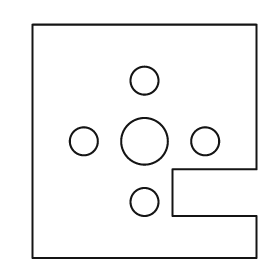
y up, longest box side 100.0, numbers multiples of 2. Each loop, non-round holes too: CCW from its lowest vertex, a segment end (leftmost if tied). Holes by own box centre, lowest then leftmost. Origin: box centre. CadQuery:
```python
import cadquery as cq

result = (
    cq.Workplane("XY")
    .moveTo(-48.0, -50.0)
    .lineTo(48.0, -50.0)
    .lineTo(48.0, -32.0)
    .lineTo(12.0, -32.0)
    .lineTo(12.0, -12.0)
    .lineTo(48.0, -12.0)
    .lineTo(48.0, 50.0)
    .lineTo(-48.0, 50.0)
    .close()
    .moveTo(0.0, -26.0)
    .circle(6.0)
    .moveTo(-26.0, 0.0)
    .circle(6.0)
    .moveTo(0.0, 0.0)
    .circle(10.0)
    .moveTo(26.0, 0.0)
    .circle(6.0)
    .moveTo(0.0, 26.0)
    .circle(6.0)
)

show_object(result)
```